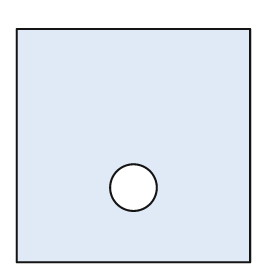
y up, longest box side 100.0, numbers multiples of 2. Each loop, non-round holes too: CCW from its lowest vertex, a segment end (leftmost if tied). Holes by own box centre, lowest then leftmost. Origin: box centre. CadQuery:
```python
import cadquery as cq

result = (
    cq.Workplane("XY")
    .moveTo(-50.0, -50.0)
    .lineTo(50.0, -50.0)
    .lineTo(50.0, 50.0)
    .lineTo(-50.0, 50.0)
    .close()
    .moveTo(0.0, -18.0)
    .circle(10.0)
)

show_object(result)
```